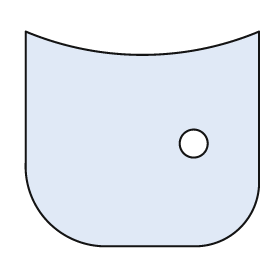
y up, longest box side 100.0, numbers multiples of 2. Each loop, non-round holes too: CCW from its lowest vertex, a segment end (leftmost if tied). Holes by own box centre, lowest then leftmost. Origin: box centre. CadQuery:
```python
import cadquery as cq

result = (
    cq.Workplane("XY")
    .moveTo(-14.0, -46.0)
    .lineTo(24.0, -46.0)
    .threePointArc((42.0, -38.0), (50.0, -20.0))
    .lineTo(50.0, 46.0)
    .threePointArc((0.0, 36.0), (-50.0, 46.0))
    .lineTo(-50.0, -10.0)
    .threePointArc((-40.0, -36.0), (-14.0, -46.0))
    .close()
    .moveTo(22.0, -2.0)
    .circle(6.0)
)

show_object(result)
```